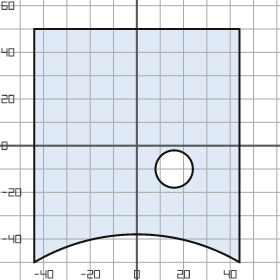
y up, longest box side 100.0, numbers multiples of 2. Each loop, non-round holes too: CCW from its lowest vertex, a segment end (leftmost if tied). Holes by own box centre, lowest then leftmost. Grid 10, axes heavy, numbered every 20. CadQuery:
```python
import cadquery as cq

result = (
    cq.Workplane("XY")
    .moveTo(-44.0, -50.0)
    .threePointArc((0.0, -38.0), (44.0, -50.0))
    .lineTo(44.0, 50.0)
    .lineTo(-44.0, 50.0)
    .close()
    .moveTo(16.0, -10.0)
    .circle(8.0)
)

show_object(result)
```